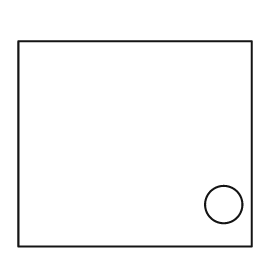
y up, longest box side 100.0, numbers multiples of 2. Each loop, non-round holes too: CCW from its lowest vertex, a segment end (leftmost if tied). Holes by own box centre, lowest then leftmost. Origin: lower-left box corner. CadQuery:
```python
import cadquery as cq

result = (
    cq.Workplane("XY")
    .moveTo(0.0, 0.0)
    .lineTo(100.0, 0.0)
    .lineTo(100.0, 88.0)
    .lineTo(0.0, 88.0)
    .close()
    .moveTo(88.0, 18.0)
    .circle(8.0)
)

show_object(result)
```